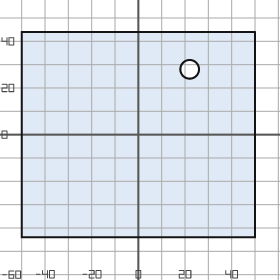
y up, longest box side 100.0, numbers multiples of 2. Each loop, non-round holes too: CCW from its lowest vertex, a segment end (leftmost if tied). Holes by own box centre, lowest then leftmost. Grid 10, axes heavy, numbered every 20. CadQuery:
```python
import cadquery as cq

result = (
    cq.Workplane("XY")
    .moveTo(-50.0, -44.0)
    .lineTo(50.0, -44.0)
    .lineTo(50.0, 44.0)
    .lineTo(-50.0, 44.0)
    .close()
    .moveTo(22.0, 28.0)
    .circle(4.0)
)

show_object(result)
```